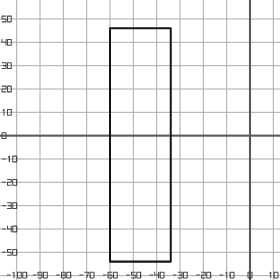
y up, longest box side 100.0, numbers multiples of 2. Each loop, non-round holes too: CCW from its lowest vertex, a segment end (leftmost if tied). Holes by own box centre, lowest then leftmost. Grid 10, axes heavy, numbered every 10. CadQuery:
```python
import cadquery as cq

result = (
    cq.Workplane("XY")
    .moveTo(-60.0, -54.0)
    .lineTo(-34.0, -54.0)
    .lineTo(-34.0, 46.0)
    .lineTo(-60.0, 46.0)
    .close()
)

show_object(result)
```